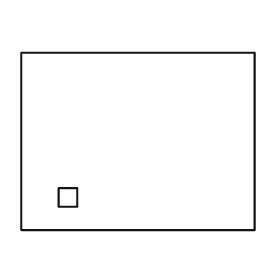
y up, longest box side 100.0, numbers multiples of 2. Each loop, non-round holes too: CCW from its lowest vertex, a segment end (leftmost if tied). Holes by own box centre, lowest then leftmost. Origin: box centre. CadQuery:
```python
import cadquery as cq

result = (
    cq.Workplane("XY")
    .moveTo(-50.0, -38.0)
    .lineTo(50.0, -38.0)
    .lineTo(50.0, 38.0)
    .lineTo(-50.0, 38.0)
    .close()
    .moveTo(-34.0, -28.0)
    .lineTo(-26.0, -28.0)
    .lineTo(-26.0, -20.0)
    .lineTo(-34.0, -20.0)
    .close()
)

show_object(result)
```